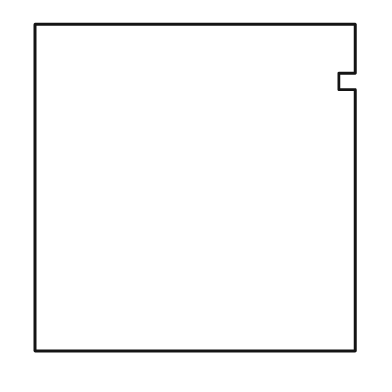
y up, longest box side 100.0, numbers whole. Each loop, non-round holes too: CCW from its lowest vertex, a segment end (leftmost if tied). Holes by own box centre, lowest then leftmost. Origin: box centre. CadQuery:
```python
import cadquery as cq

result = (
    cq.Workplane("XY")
    .moveTo(-49.0, -50.0)
    .lineTo(49.0, -50.0)
    .lineTo(49.0, 30.0)
    .lineTo(44.0, 30.0)
    .lineTo(44.0, 35.0)
    .lineTo(49.0, 35.0)
    .lineTo(49.0, 50.0)
    .lineTo(-49.0, 50.0)
    .close()
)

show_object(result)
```